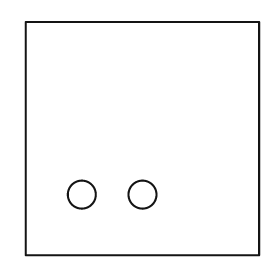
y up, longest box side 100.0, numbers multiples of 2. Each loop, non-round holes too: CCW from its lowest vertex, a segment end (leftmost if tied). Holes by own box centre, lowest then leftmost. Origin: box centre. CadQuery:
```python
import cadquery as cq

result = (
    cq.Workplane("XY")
    .moveTo(-50.0, -50.0)
    .lineTo(50.0, -50.0)
    .lineTo(50.0, 50.0)
    .lineTo(-50.0, 50.0)
    .close()
    .moveTo(-26.0, -24.0)
    .circle(6.0)
    .moveTo(0.0, -24.0)
    .circle(6.0)
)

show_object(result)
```